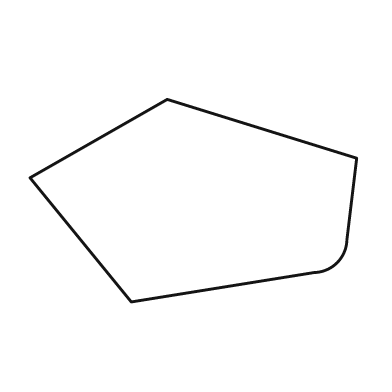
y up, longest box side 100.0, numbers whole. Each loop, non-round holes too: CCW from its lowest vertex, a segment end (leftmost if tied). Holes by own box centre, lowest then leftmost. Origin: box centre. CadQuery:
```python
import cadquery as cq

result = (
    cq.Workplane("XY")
    .moveTo(-19.0, -31.0)
    .lineTo(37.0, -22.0)
    .threePointArc((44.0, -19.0), (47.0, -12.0))
    .lineTo(50.0, 13.0)
    .lineTo(-8.0, 31.0)
    .lineTo(-50.0, 7.0)
    .close()
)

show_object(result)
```